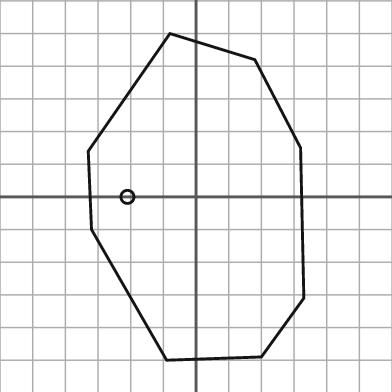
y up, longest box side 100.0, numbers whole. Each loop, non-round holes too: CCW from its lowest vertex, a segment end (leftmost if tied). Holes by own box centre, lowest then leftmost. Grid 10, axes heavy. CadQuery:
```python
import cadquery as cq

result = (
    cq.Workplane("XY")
    .moveTo(-9.0, -50.0)
    .lineTo(20.0, -49.0)
    .lineTo(33.0, -31.0)
    .lineTo(32.0, 15.0)
    .lineTo(18.0, 42.0)
    .lineTo(-8.0, 50.0)
    .lineTo(-33.0, 14.0)
    .lineTo(-32.0, -10.0)
    .close()
    .moveTo(-21.0, 0.0)
    .circle(2.0)
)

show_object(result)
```